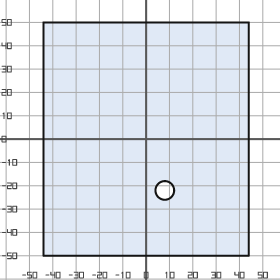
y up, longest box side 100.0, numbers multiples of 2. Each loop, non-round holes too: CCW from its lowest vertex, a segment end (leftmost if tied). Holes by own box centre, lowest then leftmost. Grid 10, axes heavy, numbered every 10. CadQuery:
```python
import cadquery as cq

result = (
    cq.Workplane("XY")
    .moveTo(-44.0, -50.0)
    .lineTo(44.0, -50.0)
    .lineTo(44.0, 50.0)
    .lineTo(-44.0, 50.0)
    .close()
    .moveTo(8.0, -22.0)
    .circle(4.0)
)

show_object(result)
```